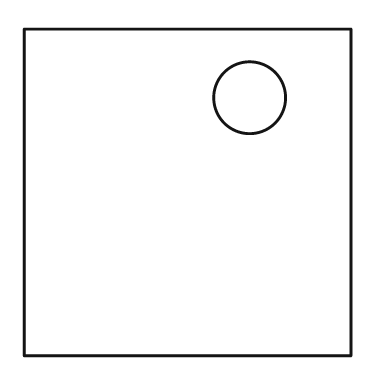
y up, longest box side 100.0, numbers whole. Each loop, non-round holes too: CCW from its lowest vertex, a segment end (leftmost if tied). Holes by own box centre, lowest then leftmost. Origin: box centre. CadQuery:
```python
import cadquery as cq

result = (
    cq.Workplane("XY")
    .moveTo(-50.0, -50.0)
    .lineTo(50.0, -50.0)
    .lineTo(50.0, 50.0)
    .lineTo(-50.0, 50.0)
    .close()
    .moveTo(19.0, 29.0)
    .circle(11.0)
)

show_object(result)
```